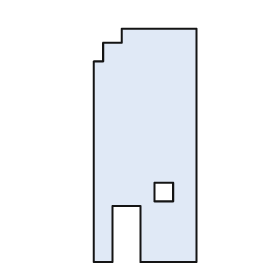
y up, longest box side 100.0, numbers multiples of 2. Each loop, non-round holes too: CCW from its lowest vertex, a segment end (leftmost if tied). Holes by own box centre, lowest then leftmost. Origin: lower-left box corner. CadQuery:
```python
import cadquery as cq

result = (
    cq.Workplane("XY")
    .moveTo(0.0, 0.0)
    .lineTo(8.0, 0.0)
    .lineTo(8.0, 24.0)
    .lineTo(20.0, 24.0)
    .lineTo(20.0, 0.0)
    .lineTo(44.0, 0.0)
    .lineTo(44.0, 100.0)
    .lineTo(12.0, 100.0)
    .lineTo(12.0, 94.0)
    .lineTo(4.0, 94.0)
    .lineTo(4.0, 86.0)
    .lineTo(0.0, 86.0)
    .close()
    .moveTo(26.0, 26.0)
    .lineTo(34.0, 26.0)
    .lineTo(34.0, 34.0)
    .lineTo(26.0, 34.0)
    .close()
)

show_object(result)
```